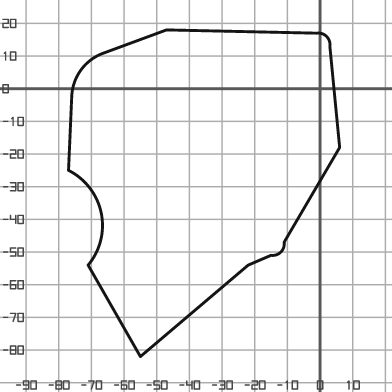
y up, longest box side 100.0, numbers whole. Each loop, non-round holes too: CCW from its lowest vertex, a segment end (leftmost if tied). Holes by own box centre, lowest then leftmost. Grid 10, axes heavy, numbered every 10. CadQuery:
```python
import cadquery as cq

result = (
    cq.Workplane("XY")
    .moveTo(-55.0, -82.0)
    .lineTo(-22.0, -54.0)
    .lineTo(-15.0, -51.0)
    .threePointArc((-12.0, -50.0), (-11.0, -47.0))
    .lineTo(6.0, -18.0)
    .lineTo(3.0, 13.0)
    .threePointArc((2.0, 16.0), (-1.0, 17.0))
    .lineTo(-47.0, 18.0)
    .lineTo(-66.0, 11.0)
    .threePointArc((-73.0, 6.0), (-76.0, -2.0))
    .lineTo(-77.0, -25.0)
    .threePointArc((-67.0, -38.0), (-71.0, -54.0))
    .close()
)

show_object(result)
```